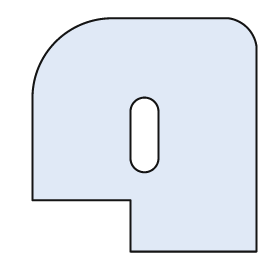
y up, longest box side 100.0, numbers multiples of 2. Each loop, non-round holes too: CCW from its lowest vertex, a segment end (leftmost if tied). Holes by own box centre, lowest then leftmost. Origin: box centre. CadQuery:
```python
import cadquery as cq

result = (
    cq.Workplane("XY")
    .moveTo(-6.0, -50.0)
    .lineTo(48.0, -50.0)
    .lineTo(48.0, 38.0)
    .threePointArc((44.0, 46.0), (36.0, 50.0))
    .lineTo(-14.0, 50.0)
    .threePointArc((-38.0, 40.0), (-48.0, 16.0))
    .lineTo(-48.0, -28.0)
    .lineTo(-6.0, -28.0)
    .close()
    .moveTo(-6.0, -10.0)
    .threePointArc((0.0, -16.0), (6.0, -10.0))
    .lineTo(6.0, 10.0)
    .threePointArc((0.0, 16.0), (-6.0, 10.0))
    .close()
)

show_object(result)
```